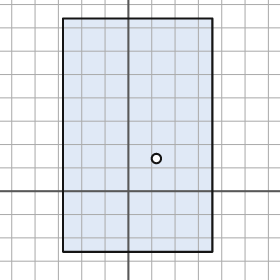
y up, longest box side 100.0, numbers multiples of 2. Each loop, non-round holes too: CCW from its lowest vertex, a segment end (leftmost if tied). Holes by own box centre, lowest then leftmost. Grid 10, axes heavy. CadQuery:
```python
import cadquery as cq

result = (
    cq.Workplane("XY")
    .moveTo(-28.0, -26.0)
    .lineTo(36.0, -26.0)
    .lineTo(36.0, 74.0)
    .lineTo(-28.0, 74.0)
    .close()
    .moveTo(12.0, 14.0)
    .circle(2.0)
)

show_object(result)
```